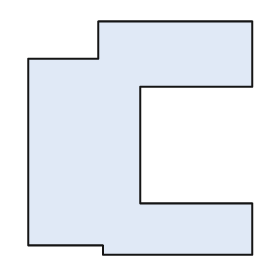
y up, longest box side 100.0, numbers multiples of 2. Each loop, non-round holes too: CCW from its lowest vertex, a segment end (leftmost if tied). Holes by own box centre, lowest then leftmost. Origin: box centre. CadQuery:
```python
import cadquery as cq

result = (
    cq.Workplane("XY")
    .moveTo(-16.0, -50.0)
    .lineTo(48.0, -50.0)
    .lineTo(48.0, -28.0)
    .lineTo(0.0, -28.0)
    .lineTo(0.0, 22.0)
    .lineTo(48.0, 22.0)
    .lineTo(48.0, 50.0)
    .lineTo(-18.0, 50.0)
    .lineTo(-18.0, 34.0)
    .lineTo(-48.0, 34.0)
    .lineTo(-48.0, -46.0)
    .lineTo(-16.0, -46.0)
    .close()
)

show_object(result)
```